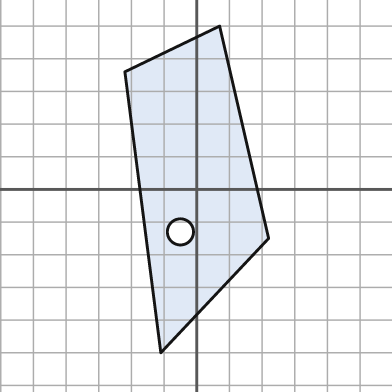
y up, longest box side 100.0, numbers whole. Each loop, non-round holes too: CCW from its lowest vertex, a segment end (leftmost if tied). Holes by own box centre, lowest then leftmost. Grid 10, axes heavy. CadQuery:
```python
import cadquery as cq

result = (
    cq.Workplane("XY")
    .moveTo(-11.0, -50.0)
    .lineTo(22.0, -15.0)
    .lineTo(7.0, 50.0)
    .lineTo(-22.0, 36.0)
    .close()
    .moveTo(-5.0, -13.0)
    .circle(4.0)
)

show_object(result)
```